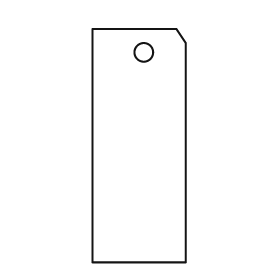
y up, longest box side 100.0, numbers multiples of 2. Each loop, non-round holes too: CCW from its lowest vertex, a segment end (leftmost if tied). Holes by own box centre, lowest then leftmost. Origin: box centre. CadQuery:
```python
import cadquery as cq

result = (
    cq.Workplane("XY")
    .moveTo(-20.0, -50.0)
    .lineTo(20.0, -50.0)
    .lineTo(20.0, 44.0)
    .lineTo(16.0, 50.0)
    .lineTo(-20.0, 50.0)
    .close()
    .moveTo(2.0, 40.0)
    .circle(4.0)
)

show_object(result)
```